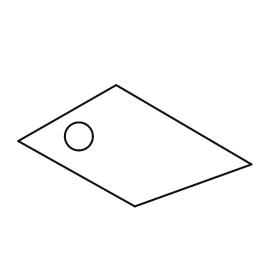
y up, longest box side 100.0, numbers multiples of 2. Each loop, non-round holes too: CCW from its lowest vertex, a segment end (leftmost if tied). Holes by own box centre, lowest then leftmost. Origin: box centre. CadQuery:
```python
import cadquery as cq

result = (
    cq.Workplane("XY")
    .moveTo(0.0, -26.0)
    .lineTo(50.0, -8.0)
    .lineTo(-8.0, 26.0)
    .lineTo(-50.0, 2.0)
    .close()
    .moveTo(-24.0, 4.0)
    .circle(6.0)
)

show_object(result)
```